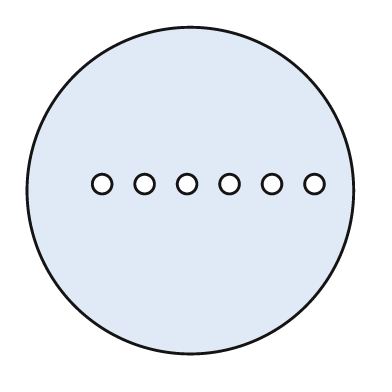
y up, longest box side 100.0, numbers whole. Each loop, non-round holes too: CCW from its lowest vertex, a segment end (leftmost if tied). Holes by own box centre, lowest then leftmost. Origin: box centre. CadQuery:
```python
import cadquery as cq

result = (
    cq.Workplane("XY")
    .moveTo(0.0, 0.0)
    .circle(50.0)
    .moveTo(-27.0, 2.0)
    .circle(3.0)
    .moveTo(-14.0, 2.0)
    .circle(3.0)
    .moveTo(-1.0, 2.0)
    .circle(3.0)
    .moveTo(12.0, 2.0)
    .circle(3.0)
    .moveTo(25.0, 2.0)
    .circle(3.0)
    .moveTo(38.0, 2.0)
    .circle(3.0)
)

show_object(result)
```